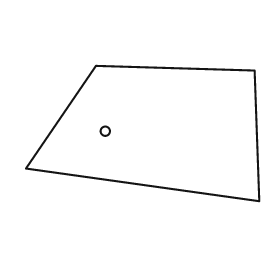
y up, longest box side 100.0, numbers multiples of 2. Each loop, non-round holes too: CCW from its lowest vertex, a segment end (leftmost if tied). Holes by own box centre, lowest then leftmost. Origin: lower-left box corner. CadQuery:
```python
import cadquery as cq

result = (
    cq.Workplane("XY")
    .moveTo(100.0, 0.0)
    .lineTo(98.0, 56.0)
    .lineTo(30.0, 58.0)
    .lineTo(0.0, 14.0)
    .close()
    .moveTo(34.0, 30.0)
    .circle(2.0)
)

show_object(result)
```